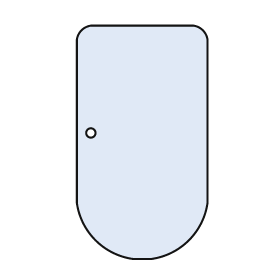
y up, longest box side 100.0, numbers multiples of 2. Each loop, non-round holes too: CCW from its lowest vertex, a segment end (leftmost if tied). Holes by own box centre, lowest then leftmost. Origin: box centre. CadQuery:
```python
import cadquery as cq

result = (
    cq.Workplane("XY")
    .moveTo(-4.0, -50.0)
    .lineTo(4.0, -50.0)
    .threePointArc((20.0, -42.0), (28.0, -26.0))
    .lineTo(28.0, 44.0)
    .threePointArc((26.0, 48.0), (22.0, 50.0))
    .lineTo(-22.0, 50.0)
    .threePointArc((-26.0, 48.0), (-28.0, 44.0))
    .lineTo(-28.0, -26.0)
    .threePointArc((-20.0, -42.0), (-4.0, -50.0))
    .close()
    .moveTo(-22.0, 4.0)
    .circle(2.0)
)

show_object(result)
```